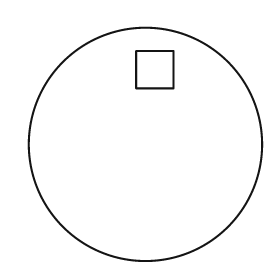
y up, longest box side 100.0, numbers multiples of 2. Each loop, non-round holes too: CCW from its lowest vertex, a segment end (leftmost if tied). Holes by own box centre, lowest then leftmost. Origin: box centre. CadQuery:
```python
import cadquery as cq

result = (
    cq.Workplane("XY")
    .moveTo(0.0, 0.0)
    .circle(50.0)
    .moveTo(-4.0, 24.0)
    .lineTo(12.0, 24.0)
    .lineTo(12.0, 40.0)
    .lineTo(-4.0, 40.0)
    .close()
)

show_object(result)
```